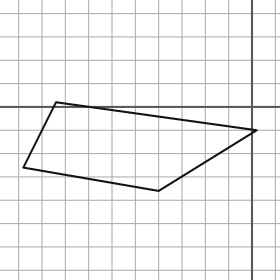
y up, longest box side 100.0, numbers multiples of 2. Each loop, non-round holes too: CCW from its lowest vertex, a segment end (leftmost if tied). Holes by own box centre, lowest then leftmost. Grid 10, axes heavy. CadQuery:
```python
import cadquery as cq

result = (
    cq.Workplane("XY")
    .moveTo(-40.0, -36.0)
    .lineTo(2.0, -10.0)
    .lineTo(-84.0, 2.0)
    .lineTo(-98.0, -26.0)
    .close()
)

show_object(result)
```